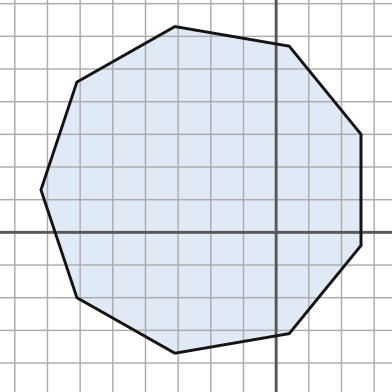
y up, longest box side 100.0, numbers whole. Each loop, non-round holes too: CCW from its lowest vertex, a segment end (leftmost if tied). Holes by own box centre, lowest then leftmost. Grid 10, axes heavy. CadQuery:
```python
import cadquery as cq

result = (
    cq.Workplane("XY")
    .moveTo(-31.0, -37.0)
    .lineTo(4.0, -31.0)
    .lineTo(26.0, -4.0)
    .lineTo(26.0, 30.0)
    .lineTo(4.0, 57.0)
    .lineTo(-31.0, 63.0)
    .lineTo(-61.0, 46.0)
    .lineTo(-72.0, 13.0)
    .lineTo(-61.0, -20.0)
    .close()
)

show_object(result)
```